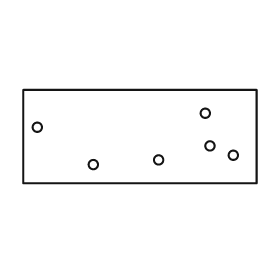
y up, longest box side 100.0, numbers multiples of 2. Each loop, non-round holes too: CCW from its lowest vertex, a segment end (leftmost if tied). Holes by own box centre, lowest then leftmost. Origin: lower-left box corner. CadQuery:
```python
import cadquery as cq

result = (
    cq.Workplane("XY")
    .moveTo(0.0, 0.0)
    .lineTo(100.0, 0.0)
    .lineTo(100.0, 40.0)
    .lineTo(0.0, 40.0)
    .close()
    .moveTo(30.0, 8.0)
    .circle(2.0)
    .moveTo(58.0, 10.0)
    .circle(2.0)
    .moveTo(90.0, 12.0)
    .circle(2.0)
    .moveTo(80.0, 16.0)
    .circle(2.0)
    .moveTo(6.0, 24.0)
    .circle(2.0)
    .moveTo(78.0, 30.0)
    .circle(2.0)
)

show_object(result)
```